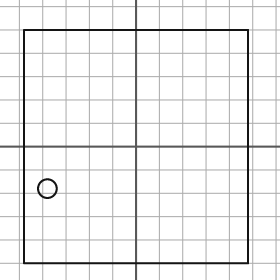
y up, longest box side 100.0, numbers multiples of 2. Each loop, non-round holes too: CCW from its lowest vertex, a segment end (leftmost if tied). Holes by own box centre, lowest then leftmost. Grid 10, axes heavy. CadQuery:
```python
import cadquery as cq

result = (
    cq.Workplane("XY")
    .moveTo(-48.0, -50.0)
    .lineTo(48.0, -50.0)
    .lineTo(48.0, 50.0)
    .lineTo(-48.0, 50.0)
    .close()
    .moveTo(-38.0, -18.0)
    .circle(4.0)
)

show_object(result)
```